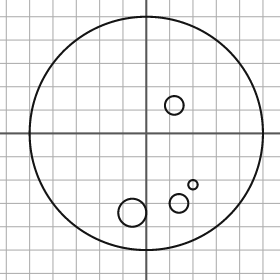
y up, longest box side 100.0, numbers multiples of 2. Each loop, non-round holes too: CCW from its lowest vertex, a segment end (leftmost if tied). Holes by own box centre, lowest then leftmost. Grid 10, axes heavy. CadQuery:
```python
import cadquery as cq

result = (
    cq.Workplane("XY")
    .moveTo(0.0, 0.0)
    .circle(50.0)
    .moveTo(-6.0, -34.0)
    .circle(6.0)
    .moveTo(14.0, -30.0)
    .circle(4.0)
    .moveTo(20.0, -22.0)
    .circle(2.0)
    .moveTo(12.0, 12.0)
    .circle(4.0)
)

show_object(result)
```